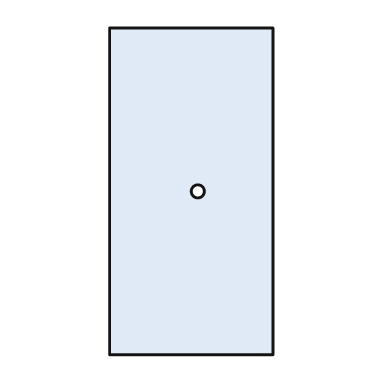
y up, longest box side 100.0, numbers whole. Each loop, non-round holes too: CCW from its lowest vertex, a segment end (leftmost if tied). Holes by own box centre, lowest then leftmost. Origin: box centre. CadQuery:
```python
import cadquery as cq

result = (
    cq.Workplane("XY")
    .moveTo(-25.0, -50.0)
    .lineTo(25.0, -50.0)
    .lineTo(25.0, 50.0)
    .lineTo(-25.0, 50.0)
    .close()
    .moveTo(2.0, 0.0)
    .circle(2.0)
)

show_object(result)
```